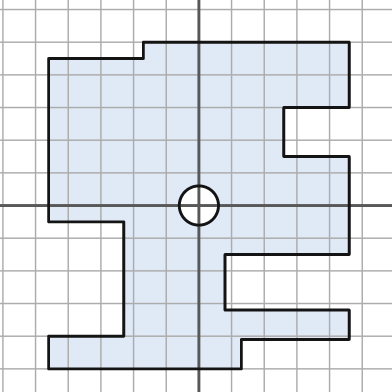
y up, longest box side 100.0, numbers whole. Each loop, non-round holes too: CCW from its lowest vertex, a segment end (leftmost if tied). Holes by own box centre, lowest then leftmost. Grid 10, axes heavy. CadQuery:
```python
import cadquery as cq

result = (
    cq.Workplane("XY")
    .moveTo(-46.0, -50.0)
    .lineTo(13.0, -50.0)
    .lineTo(13.0, -41.0)
    .lineTo(46.0, -41.0)
    .lineTo(46.0, -32.0)
    .lineTo(8.0, -32.0)
    .lineTo(8.0, -15.0)
    .lineTo(46.0, -15.0)
    .lineTo(46.0, 15.0)
    .lineTo(26.0, 15.0)
    .lineTo(26.0, 30.0)
    .lineTo(46.0, 30.0)
    .lineTo(46.0, 50.0)
    .lineTo(-17.0, 50.0)
    .lineTo(-17.0, 45.0)
    .lineTo(-46.0, 45.0)
    .lineTo(-46.0, -5.0)
    .lineTo(-23.0, -5.0)
    .lineTo(-23.0, -40.0)
    .lineTo(-46.0, -40.0)
    .close()
    .moveTo(0.0, 0.0)
    .circle(6.0)
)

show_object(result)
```